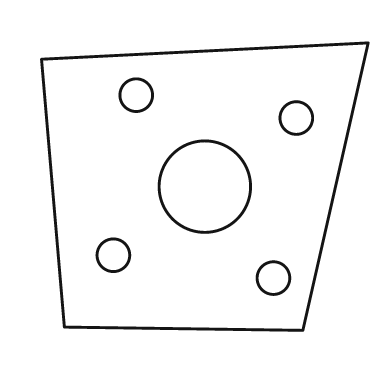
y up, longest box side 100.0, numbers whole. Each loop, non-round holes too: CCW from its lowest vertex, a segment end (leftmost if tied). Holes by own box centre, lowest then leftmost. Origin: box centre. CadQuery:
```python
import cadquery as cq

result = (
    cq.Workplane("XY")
    .moveTo(30.0, -44.0)
    .lineTo(50.0, 44.0)
    .lineTo(-50.0, 39.0)
    .lineTo(-43.0, -43.0)
    .close()
    .moveTo(21.0, -28.0)
    .circle(5.0)
    .moveTo(-28.0, -21.0)
    .circle(5.0)
    .moveTo(0.0, 0.0)
    .circle(14.0)
    .moveTo(28.0, 21.0)
    .circle(5.0)
    .moveTo(-21.0, 28.0)
    .circle(5.0)
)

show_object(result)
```